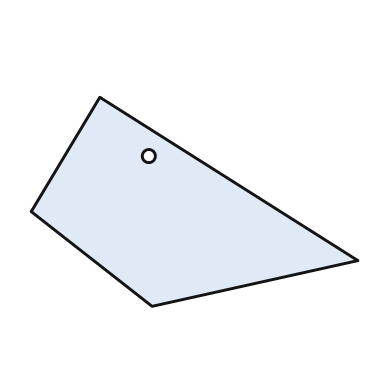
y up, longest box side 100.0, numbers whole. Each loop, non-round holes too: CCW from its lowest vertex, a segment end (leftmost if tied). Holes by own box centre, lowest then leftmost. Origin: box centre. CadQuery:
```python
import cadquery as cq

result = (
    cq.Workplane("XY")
    .moveTo(-13.0, -32.0)
    .lineTo(50.0, -18.0)
    .lineTo(-29.0, 32.0)
    .lineTo(-50.0, -3.0)
    .close()
    .moveTo(-14.0, 14.0)
    .circle(2.0)
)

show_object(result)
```